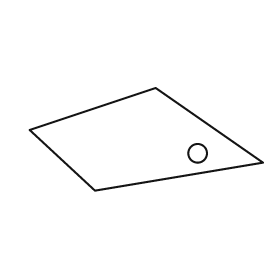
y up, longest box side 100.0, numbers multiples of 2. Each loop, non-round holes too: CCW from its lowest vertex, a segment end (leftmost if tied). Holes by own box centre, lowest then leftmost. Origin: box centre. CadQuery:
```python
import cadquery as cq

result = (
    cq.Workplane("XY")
    .moveTo(-22.0, -22.0)
    .lineTo(50.0, -10.0)
    .lineTo(4.0, 22.0)
    .lineTo(-50.0, 4.0)
    .close()
    .moveTo(22.0, -6.0)
    .circle(4.0)
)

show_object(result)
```